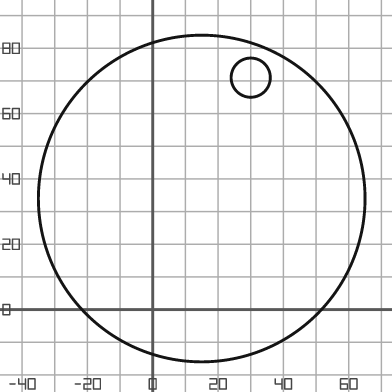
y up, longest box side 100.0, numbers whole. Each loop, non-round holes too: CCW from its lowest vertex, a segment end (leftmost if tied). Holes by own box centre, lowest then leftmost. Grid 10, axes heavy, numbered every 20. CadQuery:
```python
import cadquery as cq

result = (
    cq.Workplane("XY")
    .moveTo(15.0, 34.0)
    .circle(50.0)
    .moveTo(30.0, 71.0)
    .circle(6.0)
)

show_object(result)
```